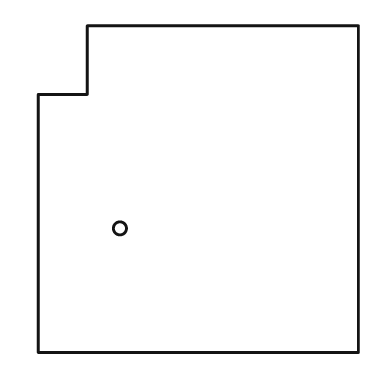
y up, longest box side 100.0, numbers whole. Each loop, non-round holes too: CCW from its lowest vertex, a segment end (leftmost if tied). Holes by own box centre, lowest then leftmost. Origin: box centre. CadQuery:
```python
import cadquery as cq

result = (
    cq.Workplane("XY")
    .moveTo(-49.0, -50.0)
    .lineTo(49.0, -50.0)
    .lineTo(49.0, 50.0)
    .lineTo(-34.0, 50.0)
    .lineTo(-34.0, 29.0)
    .lineTo(-49.0, 29.0)
    .close()
    .moveTo(-24.0, -12.0)
    .circle(2.0)
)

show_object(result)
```